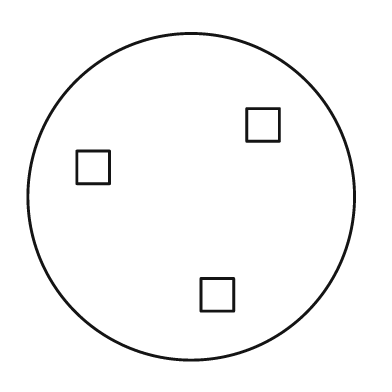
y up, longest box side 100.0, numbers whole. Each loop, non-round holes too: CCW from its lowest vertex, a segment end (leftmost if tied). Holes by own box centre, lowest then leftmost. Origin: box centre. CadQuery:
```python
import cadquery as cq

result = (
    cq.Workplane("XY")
    .moveTo(0.0, 0.0)
    .circle(50.0)
    .moveTo(3.0, -35.0)
    .lineTo(13.0, -35.0)
    .lineTo(13.0, -25.0)
    .lineTo(3.0, -25.0)
    .close()
    .moveTo(-35.0, 4.0)
    .lineTo(-25.0, 4.0)
    .lineTo(-25.0, 14.0)
    .lineTo(-35.0, 14.0)
    .close()
    .moveTo(17.0, 17.0)
    .lineTo(27.0, 17.0)
    .lineTo(27.0, 27.0)
    .lineTo(17.0, 27.0)
    .close()
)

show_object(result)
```